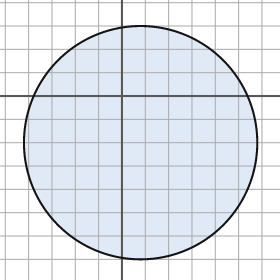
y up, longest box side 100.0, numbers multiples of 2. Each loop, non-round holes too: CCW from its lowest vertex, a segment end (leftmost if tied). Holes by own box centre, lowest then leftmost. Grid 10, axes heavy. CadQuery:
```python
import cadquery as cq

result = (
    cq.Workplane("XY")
    .moveTo(8.0, -20.0)
    .circle(50.0)
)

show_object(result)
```